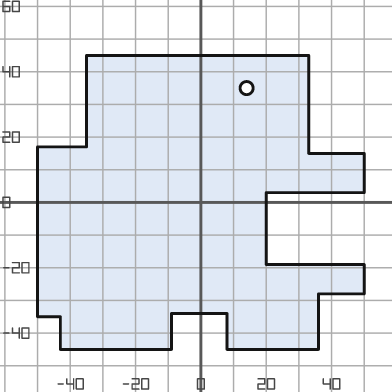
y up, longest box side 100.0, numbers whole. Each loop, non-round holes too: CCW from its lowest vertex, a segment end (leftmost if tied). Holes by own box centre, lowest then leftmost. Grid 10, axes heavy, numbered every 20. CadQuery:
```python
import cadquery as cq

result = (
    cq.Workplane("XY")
    .moveTo(-43.0, -45.0)
    .lineTo(-9.0, -45.0)
    .lineTo(-9.0, -34.0)
    .lineTo(8.0, -34.0)
    .lineTo(8.0, -45.0)
    .lineTo(36.0, -45.0)
    .lineTo(36.0, -28.0)
    .lineTo(50.0, -28.0)
    .lineTo(50.0, -19.0)
    .lineTo(20.0, -19.0)
    .lineTo(20.0, 3.0)
    .lineTo(50.0, 3.0)
    .lineTo(50.0, 15.0)
    .lineTo(33.0, 15.0)
    .lineTo(33.0, 45.0)
    .lineTo(-35.0, 45.0)
    .lineTo(-35.0, 17.0)
    .lineTo(-50.0, 17.0)
    .lineTo(-50.0, -35.0)
    .lineTo(-43.0, -35.0)
    .close()
    .moveTo(14.0, 35.0)
    .circle(2.0)
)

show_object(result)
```